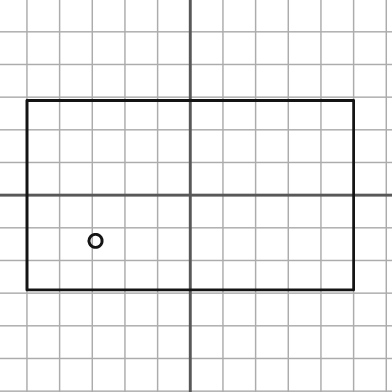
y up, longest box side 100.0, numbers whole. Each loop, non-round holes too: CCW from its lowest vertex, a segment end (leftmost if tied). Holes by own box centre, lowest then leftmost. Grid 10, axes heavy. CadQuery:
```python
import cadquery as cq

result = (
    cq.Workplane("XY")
    .moveTo(-50.0, -29.0)
    .lineTo(50.0, -29.0)
    .lineTo(50.0, 29.0)
    .lineTo(-50.0, 29.0)
    .close()
    .moveTo(-29.0, -14.0)
    .circle(2.0)
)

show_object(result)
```